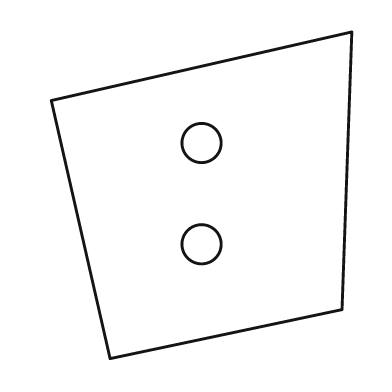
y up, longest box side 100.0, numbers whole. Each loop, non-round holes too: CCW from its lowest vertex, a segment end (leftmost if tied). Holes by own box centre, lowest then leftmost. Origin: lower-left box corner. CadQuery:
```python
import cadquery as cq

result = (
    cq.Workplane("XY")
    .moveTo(18.0, 0.0)
    .lineTo(89.0, 15.0)
    .lineTo(92.0, 100.0)
    .lineTo(0.0, 79.0)
    .close()
    .moveTo(46.0, 35.0)
    .circle(6.0)
    .moveTo(46.0, 66.0)
    .circle(6.0)
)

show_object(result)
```